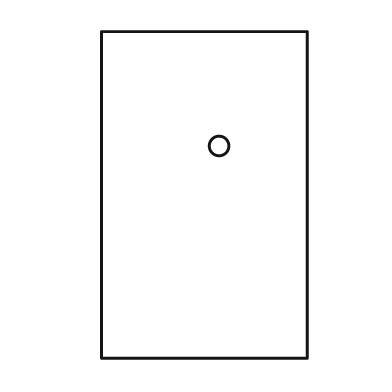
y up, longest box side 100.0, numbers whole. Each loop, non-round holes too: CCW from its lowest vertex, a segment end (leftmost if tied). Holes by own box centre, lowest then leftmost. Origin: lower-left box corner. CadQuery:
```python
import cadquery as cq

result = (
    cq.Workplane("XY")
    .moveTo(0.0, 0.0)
    .lineTo(63.0, 0.0)
    .lineTo(63.0, 100.0)
    .lineTo(0.0, 100.0)
    .close()
    .moveTo(36.0, 65.0)
    .circle(3.0)
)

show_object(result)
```